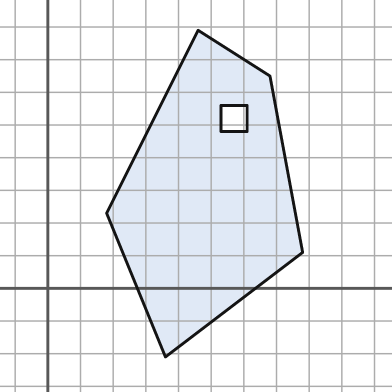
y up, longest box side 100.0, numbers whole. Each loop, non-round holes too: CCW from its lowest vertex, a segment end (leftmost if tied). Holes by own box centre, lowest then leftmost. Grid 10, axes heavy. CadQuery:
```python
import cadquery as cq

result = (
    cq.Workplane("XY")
    .moveTo(36.0, -21.0)
    .lineTo(78.0, 11.0)
    .lineTo(68.0, 65.0)
    .lineTo(46.0, 79.0)
    .lineTo(18.0, 23.0)
    .close()
    .moveTo(53.0, 48.0)
    .lineTo(61.0, 48.0)
    .lineTo(61.0, 56.0)
    .lineTo(53.0, 56.0)
    .close()
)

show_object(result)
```